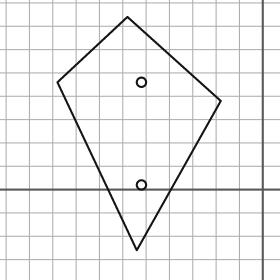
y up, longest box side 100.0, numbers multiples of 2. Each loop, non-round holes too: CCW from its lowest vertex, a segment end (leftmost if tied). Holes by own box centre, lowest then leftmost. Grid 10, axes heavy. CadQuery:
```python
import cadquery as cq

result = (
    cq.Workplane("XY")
    .moveTo(-54.0, -26.0)
    .lineTo(-18.0, 38.0)
    .lineTo(-58.0, 74.0)
    .lineTo(-88.0, 46.0)
    .close()
    .moveTo(-52.0, 2.0)
    .circle(2.0)
    .moveTo(-52.0, 46.0)
    .circle(2.0)
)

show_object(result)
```